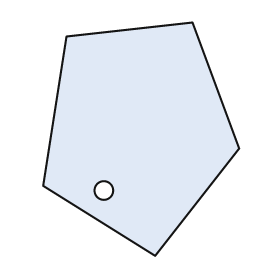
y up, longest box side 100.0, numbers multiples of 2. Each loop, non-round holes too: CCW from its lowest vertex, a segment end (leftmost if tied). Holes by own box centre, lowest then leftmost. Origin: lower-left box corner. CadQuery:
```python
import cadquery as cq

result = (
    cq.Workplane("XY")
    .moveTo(48.0, 0.0)
    .lineTo(84.0, 46.0)
    .lineTo(64.0, 100.0)
    .lineTo(10.0, 94.0)
    .lineTo(0.0, 30.0)
    .close()
    .moveTo(26.0, 28.0)
    .circle(4.0)
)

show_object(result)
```